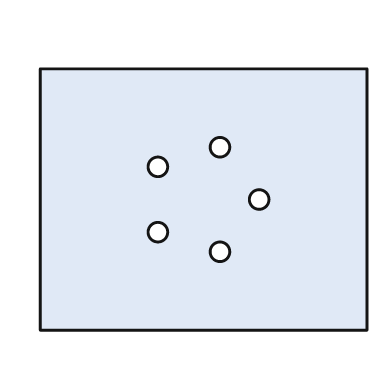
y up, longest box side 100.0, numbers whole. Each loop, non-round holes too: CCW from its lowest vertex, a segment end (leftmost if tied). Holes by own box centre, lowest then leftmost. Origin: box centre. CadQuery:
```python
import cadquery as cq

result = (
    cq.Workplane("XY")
    .moveTo(-50.0, -40.0)
    .lineTo(50.0, -40.0)
    .lineTo(50.0, 40.0)
    .lineTo(-50.0, 40.0)
    .close()
    .moveTo(5.0, -16.0)
    .circle(3.0)
    .moveTo(-14.0, -10.0)
    .circle(3.0)
    .moveTo(17.0, 0.0)
    .circle(3.0)
    .moveTo(-14.0, 10.0)
    .circle(3.0)
    .moveTo(5.0, 16.0)
    .circle(3.0)
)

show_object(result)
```